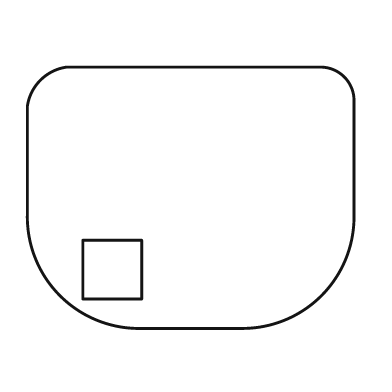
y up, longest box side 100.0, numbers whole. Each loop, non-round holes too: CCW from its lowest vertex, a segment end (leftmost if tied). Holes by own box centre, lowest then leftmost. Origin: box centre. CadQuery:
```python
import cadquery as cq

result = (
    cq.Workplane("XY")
    .moveTo(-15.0, -40.0)
    .lineTo(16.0, -40.0)
    .threePointArc((40.0, -30.0), (50.0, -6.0))
    .lineTo(50.0, 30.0)
    .threePointArc((47.0, 37.0), (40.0, 40.0))
    .lineTo(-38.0, 40.0)
    .threePointArc((-46.0, 36.0), (-50.0, 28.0))
    .lineTo(-50.0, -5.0)
    .threePointArc((-40.0, -30.0), (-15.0, -40.0))
    .close()
    .moveTo(-33.0, -31.0)
    .lineTo(-15.0, -31.0)
    .lineTo(-15.0, -13.0)
    .lineTo(-33.0, -13.0)
    .close()
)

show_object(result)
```